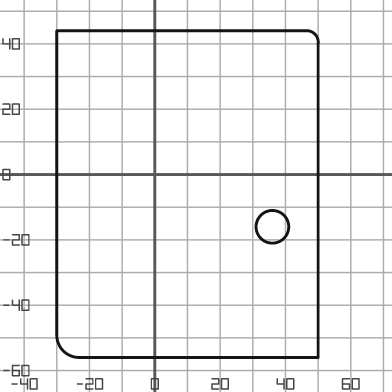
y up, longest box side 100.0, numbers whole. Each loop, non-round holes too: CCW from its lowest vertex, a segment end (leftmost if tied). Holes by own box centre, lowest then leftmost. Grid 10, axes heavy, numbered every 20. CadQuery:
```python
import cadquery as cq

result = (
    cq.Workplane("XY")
    .moveTo(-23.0, -56.0)
    .lineTo(50.0, -56.0)
    .lineTo(50.0, 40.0)
    .threePointArc((49.0, 43.0), (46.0, 44.0))
    .lineTo(-30.0, 44.0)
    .lineTo(-30.0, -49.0)
    .threePointArc((-28.0, -54.0), (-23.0, -56.0))
    .close()
    .moveTo(36.0, -16.0)
    .circle(5.0)
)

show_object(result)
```